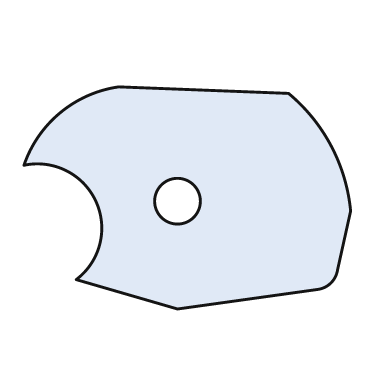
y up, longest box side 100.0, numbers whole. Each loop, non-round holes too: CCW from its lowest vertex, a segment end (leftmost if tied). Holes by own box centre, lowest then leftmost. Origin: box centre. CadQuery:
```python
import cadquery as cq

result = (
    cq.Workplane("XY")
    .moveTo(-3.0, -34.0)
    .lineTo(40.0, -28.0)
    .threePointArc((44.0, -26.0), (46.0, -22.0))
    .lineTo(50.0, -4.0)
    .threePointArc((44.0, 16.0), (31.0, 32.0))
    .lineTo(-21.0, 34.0)
    .threePointArc((-39.0, 26.0), (-50.0, 10.0))
    .threePointArc((-28.0, -1.0), (-34.0, -25.0))
    .close()
    .moveTo(-3.0, -1.0)
    .circle(7.0)
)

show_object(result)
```